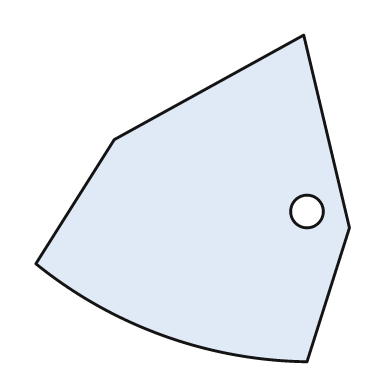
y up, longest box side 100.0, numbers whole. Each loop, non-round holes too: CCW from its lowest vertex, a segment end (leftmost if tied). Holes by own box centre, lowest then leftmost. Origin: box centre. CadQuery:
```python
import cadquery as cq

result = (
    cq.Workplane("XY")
    .moveTo(35.0, -50.0)
    .lineTo(48.0, -9.0)
    .lineTo(34.0, 50.0)
    .lineTo(-24.0, 18.0)
    .lineTo(-48.0, -20.0)
    .threePointArc((-9.0, -42.0), (35.0, -50.0))
    .close()
    .moveTo(35.0, -4.0)
    .circle(5.0)
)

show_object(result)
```